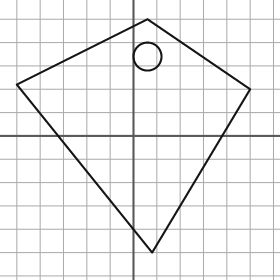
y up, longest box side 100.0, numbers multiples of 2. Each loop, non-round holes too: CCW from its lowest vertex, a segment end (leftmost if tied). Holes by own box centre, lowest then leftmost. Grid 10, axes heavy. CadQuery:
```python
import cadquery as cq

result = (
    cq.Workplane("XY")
    .moveTo(8.0, -50.0)
    .lineTo(50.0, 20.0)
    .lineTo(6.0, 50.0)
    .lineTo(-50.0, 22.0)
    .close()
    .moveTo(6.0, 34.0)
    .circle(6.0)
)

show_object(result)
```